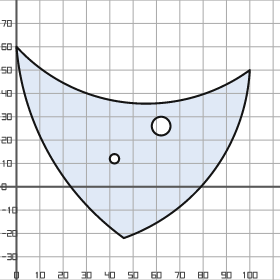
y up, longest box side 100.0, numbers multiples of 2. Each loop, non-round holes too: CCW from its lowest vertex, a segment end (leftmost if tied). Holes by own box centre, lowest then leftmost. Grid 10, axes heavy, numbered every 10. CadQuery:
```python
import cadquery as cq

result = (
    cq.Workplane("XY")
    .moveTo(46.0, -22.0)
    .threePointArc((84.0, 6.0), (100.0, 50.0))
    .threePointArc((48.0, 36.0), (0.0, 60.0))
    .threePointArc((14.0, 14.0), (46.0, -22.0))
    .close()
    .moveTo(42.0, 12.0)
    .circle(2.0)
    .moveTo(62.0, 26.0)
    .circle(4.0)
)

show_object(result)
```